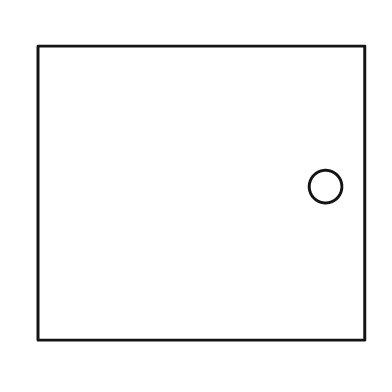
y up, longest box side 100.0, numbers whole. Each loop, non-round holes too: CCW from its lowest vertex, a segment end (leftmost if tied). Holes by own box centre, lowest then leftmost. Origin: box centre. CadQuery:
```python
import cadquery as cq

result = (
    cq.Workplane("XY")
    .moveTo(-50.0, -45.0)
    .lineTo(50.0, -45.0)
    .lineTo(50.0, 45.0)
    .lineTo(-50.0, 45.0)
    .close()
    .moveTo(38.0, 2.0)
    .circle(5.0)
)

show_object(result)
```